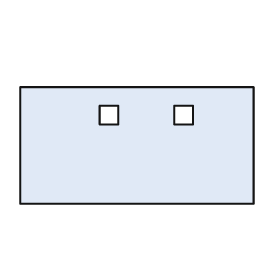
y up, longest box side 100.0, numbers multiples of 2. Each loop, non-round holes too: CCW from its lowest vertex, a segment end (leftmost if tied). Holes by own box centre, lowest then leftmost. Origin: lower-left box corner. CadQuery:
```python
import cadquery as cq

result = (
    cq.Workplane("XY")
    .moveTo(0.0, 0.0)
    .lineTo(100.0, 0.0)
    .lineTo(100.0, 50.0)
    .lineTo(0.0, 50.0)
    .close()
    .moveTo(34.0, 34.0)
    .lineTo(42.0, 34.0)
    .lineTo(42.0, 42.0)
    .lineTo(34.0, 42.0)
    .close()
    .moveTo(66.0, 34.0)
    .lineTo(74.0, 34.0)
    .lineTo(74.0, 42.0)
    .lineTo(66.0, 42.0)
    .close()
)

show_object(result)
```